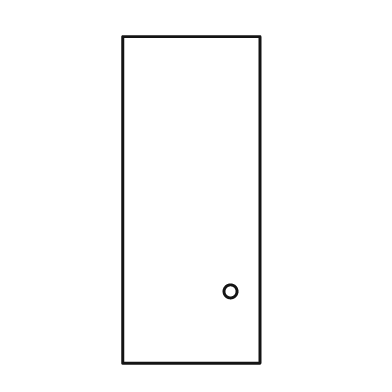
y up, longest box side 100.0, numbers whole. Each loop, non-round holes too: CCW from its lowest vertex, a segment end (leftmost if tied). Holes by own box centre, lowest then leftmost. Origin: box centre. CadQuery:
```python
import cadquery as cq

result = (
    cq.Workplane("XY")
    .moveTo(-21.0, -50.0)
    .lineTo(21.0, -50.0)
    .lineTo(21.0, 50.0)
    .lineTo(-21.0, 50.0)
    .close()
    .moveTo(12.0, -28.0)
    .circle(2.0)
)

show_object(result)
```